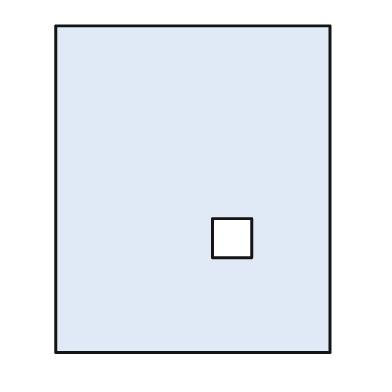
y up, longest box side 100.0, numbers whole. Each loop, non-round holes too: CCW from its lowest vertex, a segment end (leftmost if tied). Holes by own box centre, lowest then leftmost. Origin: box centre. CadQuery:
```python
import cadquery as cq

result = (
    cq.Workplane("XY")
    .moveTo(-42.0, -50.0)
    .lineTo(42.0, -50.0)
    .lineTo(42.0, 50.0)
    .lineTo(-42.0, 50.0)
    .close()
    .moveTo(6.0, -21.0)
    .lineTo(18.0, -21.0)
    .lineTo(18.0, -9.0)
    .lineTo(6.0, -9.0)
    .close()
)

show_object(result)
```